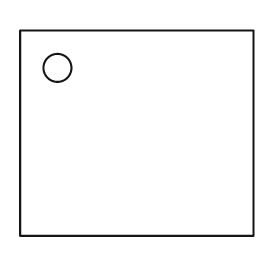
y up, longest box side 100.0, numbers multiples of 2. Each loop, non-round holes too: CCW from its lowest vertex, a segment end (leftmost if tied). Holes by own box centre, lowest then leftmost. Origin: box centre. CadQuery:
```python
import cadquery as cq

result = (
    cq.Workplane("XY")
    .moveTo(-50.0, -44.0)
    .lineTo(50.0, -44.0)
    .lineTo(50.0, 44.0)
    .lineTo(-50.0, 44.0)
    .close()
    .moveTo(-34.0, 28.0)
    .circle(6.0)
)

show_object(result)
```